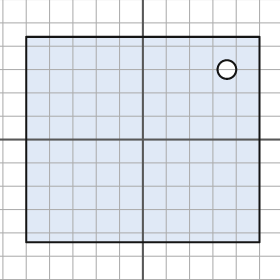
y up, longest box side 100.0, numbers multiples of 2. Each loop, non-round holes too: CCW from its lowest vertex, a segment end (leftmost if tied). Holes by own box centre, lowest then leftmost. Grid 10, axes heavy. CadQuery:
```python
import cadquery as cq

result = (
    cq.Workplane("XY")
    .moveTo(-50.0, -44.0)
    .lineTo(50.0, -44.0)
    .lineTo(50.0, 44.0)
    .lineTo(-50.0, 44.0)
    .close()
    .moveTo(36.0, 30.0)
    .circle(4.0)
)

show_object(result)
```